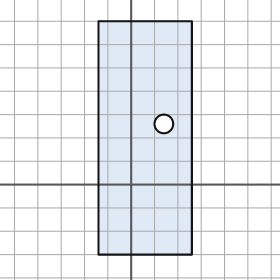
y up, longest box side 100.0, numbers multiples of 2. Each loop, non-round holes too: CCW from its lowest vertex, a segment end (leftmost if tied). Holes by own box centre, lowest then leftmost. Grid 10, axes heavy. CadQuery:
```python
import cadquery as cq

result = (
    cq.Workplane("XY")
    .moveTo(-14.0, -30.0)
    .lineTo(26.0, -30.0)
    .lineTo(26.0, 70.0)
    .lineTo(-14.0, 70.0)
    .close()
    .moveTo(14.0, 26.0)
    .circle(4.0)
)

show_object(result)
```